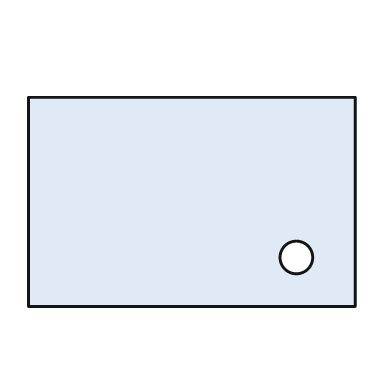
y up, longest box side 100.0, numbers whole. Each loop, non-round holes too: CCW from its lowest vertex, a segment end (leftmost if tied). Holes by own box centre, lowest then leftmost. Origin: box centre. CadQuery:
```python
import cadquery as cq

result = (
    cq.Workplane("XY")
    .moveTo(-50.0, -32.0)
    .lineTo(50.0, -32.0)
    .lineTo(50.0, 32.0)
    .lineTo(-50.0, 32.0)
    .close()
    .moveTo(32.0, -17.0)
    .circle(5.0)
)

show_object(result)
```